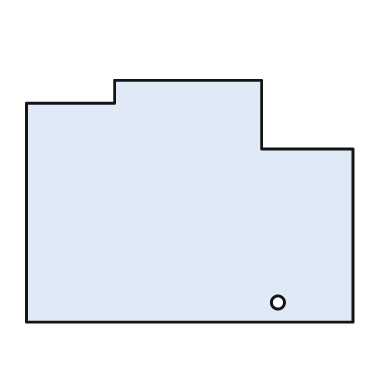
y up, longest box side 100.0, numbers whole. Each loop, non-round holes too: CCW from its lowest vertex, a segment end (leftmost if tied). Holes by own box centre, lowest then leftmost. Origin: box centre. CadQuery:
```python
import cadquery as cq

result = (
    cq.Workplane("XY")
    .moveTo(-50.0, -37.0)
    .lineTo(50.0, -37.0)
    .lineTo(50.0, 16.0)
    .lineTo(22.0, 16.0)
    .lineTo(22.0, 37.0)
    .lineTo(-23.0, 37.0)
    .lineTo(-23.0, 30.0)
    .lineTo(-50.0, 30.0)
    .close()
    .moveTo(27.0, -31.0)
    .circle(2.0)
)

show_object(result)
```